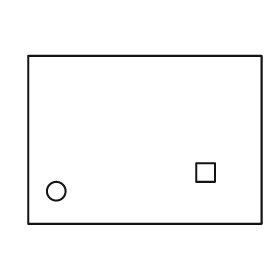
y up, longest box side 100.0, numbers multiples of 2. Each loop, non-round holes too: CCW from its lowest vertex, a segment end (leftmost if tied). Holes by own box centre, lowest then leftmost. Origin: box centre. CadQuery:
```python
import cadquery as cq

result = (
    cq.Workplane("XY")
    .moveTo(-50.0, -36.0)
    .lineTo(50.0, -36.0)
    .lineTo(50.0, 36.0)
    .lineTo(-50.0, 36.0)
    .close()
    .moveTo(-38.0, -22.0)
    .circle(4.0)
    .moveTo(22.0, -18.0)
    .lineTo(30.0, -18.0)
    .lineTo(30.0, -10.0)
    .lineTo(22.0, -10.0)
    .close()
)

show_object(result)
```